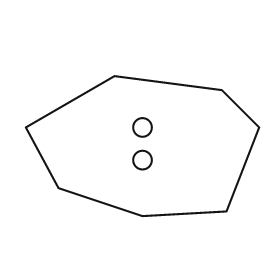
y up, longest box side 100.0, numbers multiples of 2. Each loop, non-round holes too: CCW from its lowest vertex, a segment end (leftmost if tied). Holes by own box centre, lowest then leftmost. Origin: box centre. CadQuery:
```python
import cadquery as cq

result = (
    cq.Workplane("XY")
    .moveTo(0.0, -30.0)
    .lineTo(36.0, -28.0)
    .lineTo(50.0, 8.0)
    .lineTo(34.0, 24.0)
    .lineTo(-12.0, 30.0)
    .lineTo(-50.0, 8.0)
    .lineTo(-36.0, -18.0)
    .close()
    .moveTo(0.0, -6.0)
    .circle(4.0)
    .moveTo(0.0, 8.0)
    .circle(4.0)
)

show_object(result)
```